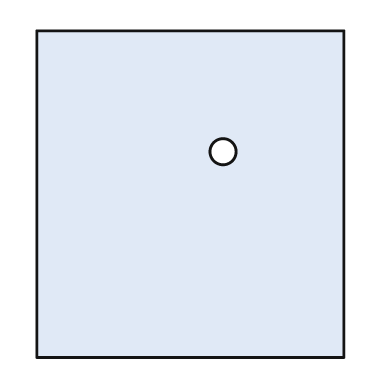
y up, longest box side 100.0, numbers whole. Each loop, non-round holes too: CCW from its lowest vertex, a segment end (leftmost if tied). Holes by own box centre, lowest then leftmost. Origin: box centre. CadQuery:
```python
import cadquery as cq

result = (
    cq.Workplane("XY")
    .moveTo(-47.0, -50.0)
    .lineTo(47.0, -50.0)
    .lineTo(47.0, 50.0)
    .lineTo(-47.0, 50.0)
    .close()
    .moveTo(10.0, 13.0)
    .circle(4.0)
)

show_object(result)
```